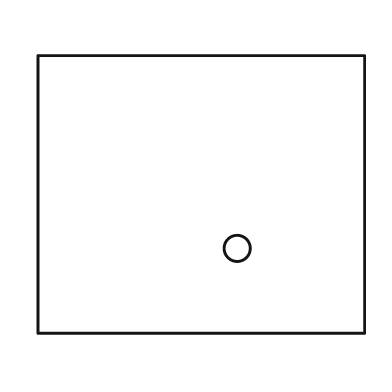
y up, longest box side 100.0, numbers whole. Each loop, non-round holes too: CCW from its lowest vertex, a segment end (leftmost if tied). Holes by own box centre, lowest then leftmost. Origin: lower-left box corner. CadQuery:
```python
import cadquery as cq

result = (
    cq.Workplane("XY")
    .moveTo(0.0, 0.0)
    .lineTo(100.0, 0.0)
    .lineTo(100.0, 85.0)
    .lineTo(0.0, 85.0)
    .close()
    .moveTo(61.0, 26.0)
    .circle(4.0)
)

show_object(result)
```